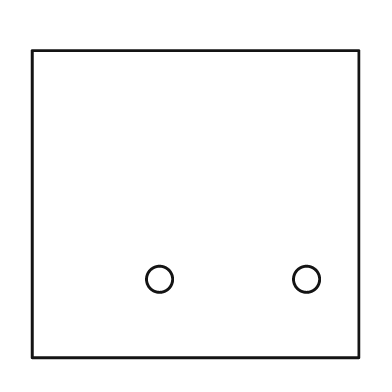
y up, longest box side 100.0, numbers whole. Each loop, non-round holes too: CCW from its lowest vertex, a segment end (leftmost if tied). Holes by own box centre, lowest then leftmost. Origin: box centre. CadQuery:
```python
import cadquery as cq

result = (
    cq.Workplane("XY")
    .moveTo(-50.0, -47.0)
    .lineTo(50.0, -47.0)
    .lineTo(50.0, 47.0)
    .lineTo(-50.0, 47.0)
    .close()
    .moveTo(-11.0, -23.0)
    .circle(4.0)
    .moveTo(34.0, -23.0)
    .circle(4.0)
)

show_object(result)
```